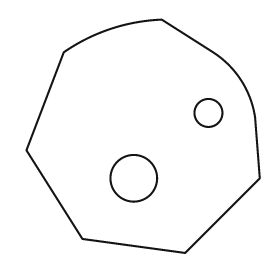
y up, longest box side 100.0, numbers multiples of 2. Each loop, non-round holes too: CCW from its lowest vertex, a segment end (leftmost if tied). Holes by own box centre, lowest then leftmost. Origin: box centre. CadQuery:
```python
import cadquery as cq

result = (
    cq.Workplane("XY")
    .moveTo(18.0, -50.0)
    .lineTo(50.0, -18.0)
    .lineTo(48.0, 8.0)
    .threePointArc((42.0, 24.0), (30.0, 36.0))
    .lineTo(8.0, 50.0)
    .threePointArc((-14.0, 46.0), (-34.0, 36.0))
    .lineTo(-50.0, -6.0)
    .lineTo(-26.0, -44.0)
    .close()
    .moveTo(-4.0, -18.0)
    .circle(10.0)
    .moveTo(28.0, 10.0)
    .circle(6.0)
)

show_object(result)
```